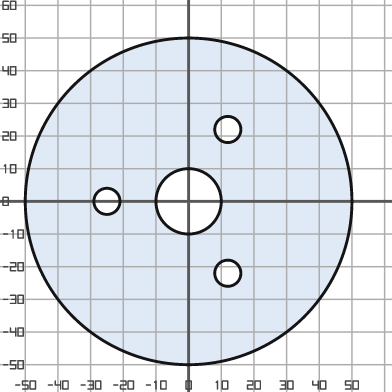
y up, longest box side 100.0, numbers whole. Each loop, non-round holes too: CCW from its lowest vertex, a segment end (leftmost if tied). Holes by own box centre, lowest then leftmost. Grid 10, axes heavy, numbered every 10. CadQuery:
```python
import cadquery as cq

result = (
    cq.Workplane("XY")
    .moveTo(0.0, 0.0)
    .circle(50.0)
    .moveTo(12.0, -22.0)
    .circle(4.0)
    .moveTo(-25.0, 0.0)
    .circle(4.0)
    .moveTo(0.0, 0.0)
    .circle(10.0)
    .moveTo(12.0, 22.0)
    .circle(4.0)
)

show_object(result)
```